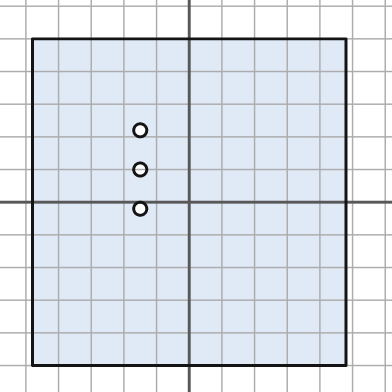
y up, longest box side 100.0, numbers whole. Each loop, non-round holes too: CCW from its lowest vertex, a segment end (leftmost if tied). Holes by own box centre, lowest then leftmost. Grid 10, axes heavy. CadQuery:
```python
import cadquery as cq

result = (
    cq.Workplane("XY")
    .moveTo(-48.0, -50.0)
    .lineTo(48.0, -50.0)
    .lineTo(48.0, 50.0)
    .lineTo(-48.0, 50.0)
    .close()
    .moveTo(-15.0, -2.0)
    .circle(2.0)
    .moveTo(-15.0, 10.0)
    .circle(2.0)
    .moveTo(-15.0, 22.0)
    .circle(2.0)
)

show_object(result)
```